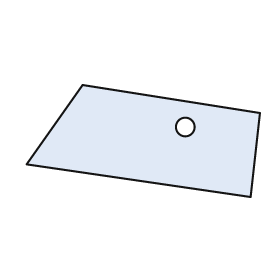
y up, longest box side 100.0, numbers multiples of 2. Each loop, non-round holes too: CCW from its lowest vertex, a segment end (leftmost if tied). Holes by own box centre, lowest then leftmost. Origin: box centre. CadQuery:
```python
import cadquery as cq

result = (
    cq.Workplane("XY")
    .moveTo(46.0, -24.0)
    .lineTo(50.0, 12.0)
    .lineTo(-26.0, 24.0)
    .lineTo(-50.0, -10.0)
    .close()
    .moveTo(18.0, 6.0)
    .circle(4.0)
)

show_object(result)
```